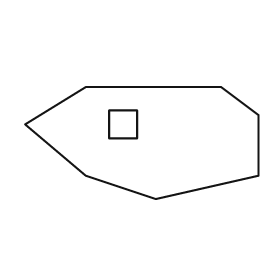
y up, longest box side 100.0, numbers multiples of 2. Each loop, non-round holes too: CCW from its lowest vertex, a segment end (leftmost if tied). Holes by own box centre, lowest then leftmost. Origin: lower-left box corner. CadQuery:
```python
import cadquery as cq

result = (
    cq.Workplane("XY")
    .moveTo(56.0, 0.0)
    .lineTo(100.0, 10.0)
    .lineTo(100.0, 36.0)
    .lineTo(84.0, 48.0)
    .lineTo(26.0, 48.0)
    .lineTo(0.0, 32.0)
    .lineTo(26.0, 10.0)
    .close()
    .moveTo(36.0, 26.0)
    .lineTo(48.0, 26.0)
    .lineTo(48.0, 38.0)
    .lineTo(36.0, 38.0)
    .close()
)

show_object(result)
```